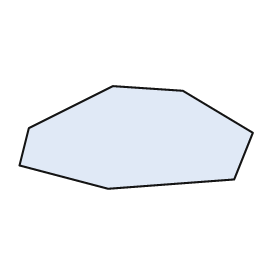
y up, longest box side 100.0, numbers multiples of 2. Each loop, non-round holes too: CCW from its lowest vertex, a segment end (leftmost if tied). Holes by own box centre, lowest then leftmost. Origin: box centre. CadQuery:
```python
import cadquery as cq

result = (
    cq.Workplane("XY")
    .moveTo(-12.0, -22.0)
    .lineTo(42.0, -18.0)
    .lineTo(50.0, 2.0)
    .lineTo(20.0, 20.0)
    .lineTo(-10.0, 22.0)
    .lineTo(-46.0, 4.0)
    .lineTo(-50.0, -12.0)
    .close()
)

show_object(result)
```